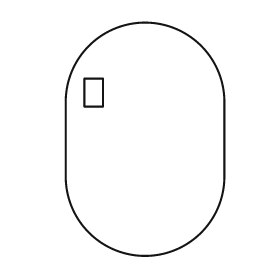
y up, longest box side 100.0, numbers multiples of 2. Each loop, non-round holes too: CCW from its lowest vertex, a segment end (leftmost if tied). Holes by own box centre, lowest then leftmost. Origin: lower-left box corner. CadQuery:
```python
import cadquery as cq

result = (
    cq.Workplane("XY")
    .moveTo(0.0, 34.0)
    .threePointArc((34.0, 0.0), (68.0, 34.0))
    .lineTo(68.0, 66.0)
    .threePointArc((34.0, 100.0), (0.0, 66.0))
    .close()
    .moveTo(8.0, 64.0)
    .lineTo(16.0, 64.0)
    .lineTo(16.0, 76.0)
    .lineTo(8.0, 76.0)
    .close()
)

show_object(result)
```